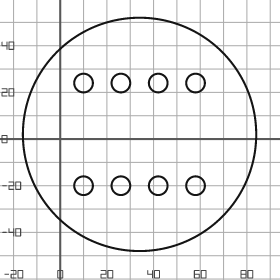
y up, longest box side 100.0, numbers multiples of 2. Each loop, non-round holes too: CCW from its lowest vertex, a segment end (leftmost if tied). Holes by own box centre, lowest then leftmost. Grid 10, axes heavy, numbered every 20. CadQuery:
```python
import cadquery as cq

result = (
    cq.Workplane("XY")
    .moveTo(34.0, 2.0)
    .circle(50.0)
    .moveTo(10.0, -20.0)
    .circle(4.0)
    .moveTo(26.0, -20.0)
    .circle(4.0)
    .moveTo(42.0, -20.0)
    .circle(4.0)
    .moveTo(58.0, -20.0)
    .circle(4.0)
    .moveTo(10.0, 24.0)
    .circle(4.0)
    .moveTo(26.0, 24.0)
    .circle(4.0)
    .moveTo(42.0, 24.0)
    .circle(4.0)
    .moveTo(58.0, 24.0)
    .circle(4.0)
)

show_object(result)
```